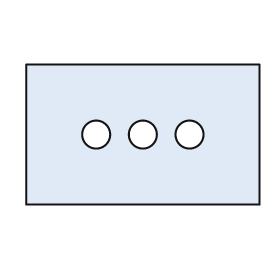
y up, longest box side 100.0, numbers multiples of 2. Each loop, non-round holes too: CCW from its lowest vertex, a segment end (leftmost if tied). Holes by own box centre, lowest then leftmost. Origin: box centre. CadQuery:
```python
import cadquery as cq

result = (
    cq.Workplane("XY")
    .moveTo(-50.0, -30.0)
    .lineTo(50.0, -30.0)
    .lineTo(50.0, 30.0)
    .lineTo(-50.0, 30.0)
    .close()
    .moveTo(-20.0, 0.0)
    .circle(6.0)
    .moveTo(0.0, 0.0)
    .circle(6.0)
    .moveTo(20.0, 0.0)
    .circle(6.0)
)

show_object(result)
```